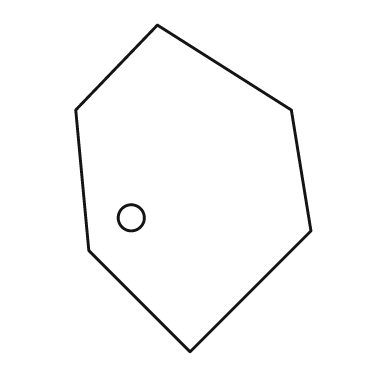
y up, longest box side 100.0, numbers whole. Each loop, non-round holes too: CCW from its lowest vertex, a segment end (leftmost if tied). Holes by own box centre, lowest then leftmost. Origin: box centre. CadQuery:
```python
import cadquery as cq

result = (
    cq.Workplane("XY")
    .moveTo(-1.0, -50.0)
    .lineTo(36.0, -13.0)
    .lineTo(30.0, 24.0)
    .lineTo(-11.0, 50.0)
    .lineTo(-36.0, 24.0)
    .lineTo(-32.0, -19.0)
    .close()
    .moveTo(-19.0, -9.0)
    .circle(4.0)
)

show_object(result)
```